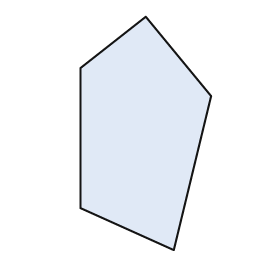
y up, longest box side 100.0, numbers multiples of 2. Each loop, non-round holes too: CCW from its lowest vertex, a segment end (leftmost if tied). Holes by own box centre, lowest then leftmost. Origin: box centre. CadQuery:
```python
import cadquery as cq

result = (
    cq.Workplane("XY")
    .moveTo(12.0, -50.0)
    .lineTo(28.0, 16.0)
    .lineTo(0.0, 50.0)
    .lineTo(-28.0, 28.0)
    .lineTo(-28.0, -32.0)
    .close()
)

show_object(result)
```